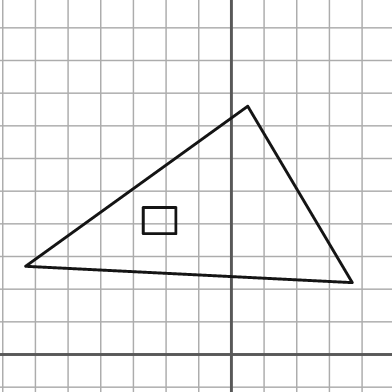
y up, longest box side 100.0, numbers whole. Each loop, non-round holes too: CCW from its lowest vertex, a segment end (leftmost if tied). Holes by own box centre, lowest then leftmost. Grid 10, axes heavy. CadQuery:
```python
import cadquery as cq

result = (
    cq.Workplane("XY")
    .moveTo(37.0, 22.0)
    .lineTo(5.0, 76.0)
    .lineTo(-63.0, 27.0)
    .close()
    .moveTo(-27.0, 37.0)
    .lineTo(-17.0, 37.0)
    .lineTo(-17.0, 45.0)
    .lineTo(-27.0, 45.0)
    .close()
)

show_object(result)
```